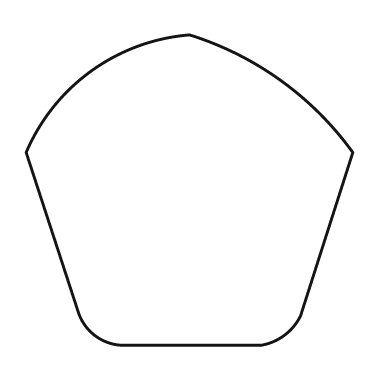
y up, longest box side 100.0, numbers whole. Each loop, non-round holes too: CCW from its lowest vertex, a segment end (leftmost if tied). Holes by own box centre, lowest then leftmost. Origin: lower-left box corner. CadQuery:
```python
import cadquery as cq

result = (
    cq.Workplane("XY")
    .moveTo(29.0, 0.0)
    .lineTo(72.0, 0.0)
    .threePointArc((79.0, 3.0), (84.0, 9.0))
    .lineTo(100.0, 59.0)
    .threePointArc((78.0, 81.0), (50.0, 95.0))
    .threePointArc((20.0, 84.0), (0.0, 59.0))
    .lineTo(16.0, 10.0)
    .threePointArc((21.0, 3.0), (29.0, 0.0))
    .close()
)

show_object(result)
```